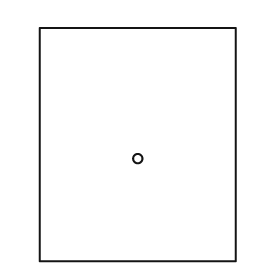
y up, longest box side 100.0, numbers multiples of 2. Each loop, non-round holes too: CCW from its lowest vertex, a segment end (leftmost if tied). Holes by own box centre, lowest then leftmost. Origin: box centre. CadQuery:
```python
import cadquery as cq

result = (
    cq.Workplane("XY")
    .moveTo(-42.0, -50.0)
    .lineTo(42.0, -50.0)
    .lineTo(42.0, 50.0)
    .lineTo(-42.0, 50.0)
    .close()
    .moveTo(0.0, -6.0)
    .circle(2.0)
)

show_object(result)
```